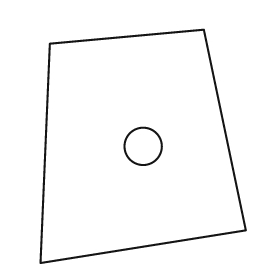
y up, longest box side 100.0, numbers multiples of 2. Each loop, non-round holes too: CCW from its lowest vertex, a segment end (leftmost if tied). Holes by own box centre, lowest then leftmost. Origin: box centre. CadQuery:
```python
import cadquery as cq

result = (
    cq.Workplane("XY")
    .moveTo(-44.0, -50.0)
    .lineTo(44.0, -36.0)
    .lineTo(26.0, 50.0)
    .lineTo(-40.0, 44.0)
    .close()
    .moveTo(0.0, 0.0)
    .circle(8.0)
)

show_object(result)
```